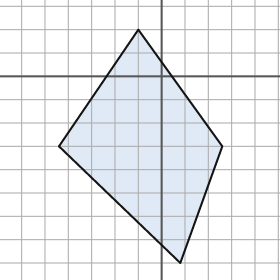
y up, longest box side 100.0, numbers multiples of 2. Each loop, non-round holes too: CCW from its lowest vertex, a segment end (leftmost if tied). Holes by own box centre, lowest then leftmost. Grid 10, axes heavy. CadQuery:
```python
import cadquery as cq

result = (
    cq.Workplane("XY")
    .moveTo(8.0, -80.0)
    .lineTo(26.0, -30.0)
    .lineTo(-10.0, 20.0)
    .lineTo(-44.0, -30.0)
    .close()
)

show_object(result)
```